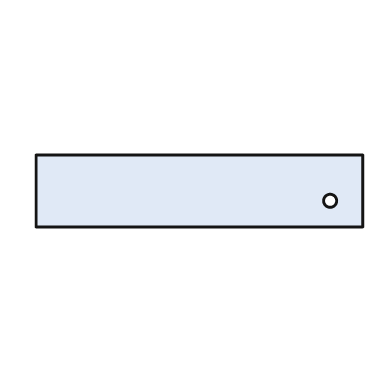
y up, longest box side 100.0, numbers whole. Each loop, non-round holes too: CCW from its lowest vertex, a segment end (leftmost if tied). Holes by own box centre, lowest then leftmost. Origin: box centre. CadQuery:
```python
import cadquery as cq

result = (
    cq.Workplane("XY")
    .moveTo(-50.0, -11.0)
    .lineTo(50.0, -11.0)
    .lineTo(50.0, 11.0)
    .lineTo(-50.0, 11.0)
    .close()
    .moveTo(40.0, -3.0)
    .circle(2.0)
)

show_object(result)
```